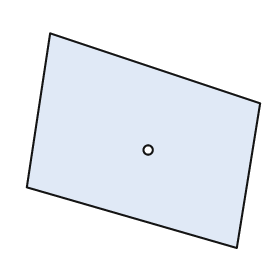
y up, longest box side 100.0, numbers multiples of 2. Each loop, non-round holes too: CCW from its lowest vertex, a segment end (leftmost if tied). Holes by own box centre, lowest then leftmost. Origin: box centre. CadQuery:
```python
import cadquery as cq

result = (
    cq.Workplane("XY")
    .moveTo(40.0, -46.0)
    .lineTo(50.0, 16.0)
    .lineTo(-40.0, 46.0)
    .lineTo(-50.0, -20.0)
    .close()
    .moveTo(2.0, -4.0)
    .circle(2.0)
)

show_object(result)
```